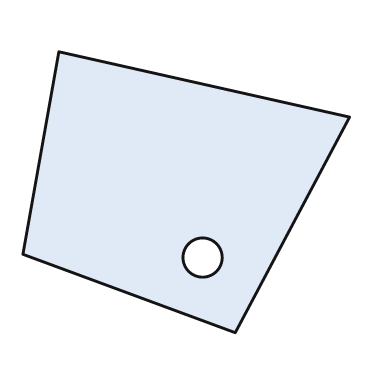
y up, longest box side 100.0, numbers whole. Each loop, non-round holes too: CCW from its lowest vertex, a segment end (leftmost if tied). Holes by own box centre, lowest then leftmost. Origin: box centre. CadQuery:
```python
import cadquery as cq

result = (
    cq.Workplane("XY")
    .moveTo(15.0, -43.0)
    .lineTo(50.0, 23.0)
    .lineTo(-39.0, 43.0)
    .lineTo(-50.0, -19.0)
    .close()
    .moveTo(5.0, -20.0)
    .circle(6.0)
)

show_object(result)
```